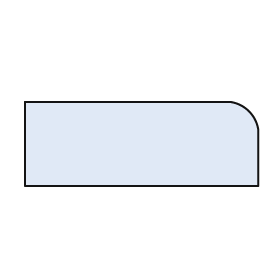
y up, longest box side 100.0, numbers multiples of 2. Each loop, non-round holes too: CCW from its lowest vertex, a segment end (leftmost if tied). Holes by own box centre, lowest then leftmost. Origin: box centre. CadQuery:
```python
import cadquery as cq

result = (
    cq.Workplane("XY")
    .moveTo(-50.0, -18.0)
    .lineTo(50.0, -18.0)
    .lineTo(50.0, 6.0)
    .threePointArc((46.0, 14.0), (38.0, 18.0))
    .lineTo(-50.0, 18.0)
    .close()
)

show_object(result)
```